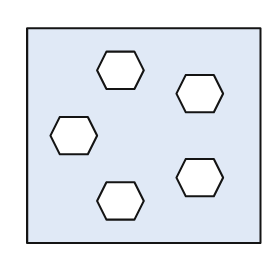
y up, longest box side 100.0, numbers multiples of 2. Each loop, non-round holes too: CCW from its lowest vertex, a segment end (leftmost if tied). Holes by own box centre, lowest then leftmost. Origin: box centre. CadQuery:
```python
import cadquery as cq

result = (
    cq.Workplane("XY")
    .moveTo(-50.0, -46.0)
    .lineTo(50.0, -46.0)
    .lineTo(50.0, 46.0)
    .lineTo(-50.0, 46.0)
    .close()
    .moveTo(-16.0, -36.0)
    .lineTo(-4.0, -36.0)
    .lineTo(0.0, -28.0)
    .lineTo(-4.0, -20.0)
    .lineTo(-16.0, -20.0)
    .lineTo(-20.0, -28.0)
    .close()
    .moveTo(18.0, -26.0)
    .lineTo(30.0, -26.0)
    .lineTo(34.0, -18.0)
    .lineTo(30.0, -10.0)
    .lineTo(18.0, -10.0)
    .lineTo(14.0, -18.0)
    .close()
    .moveTo(-36.0, -8.0)
    .lineTo(-24.0, -8.0)
    .lineTo(-20.0, 0.0)
    .lineTo(-24.0, 8.0)
    .lineTo(-36.0, 8.0)
    .lineTo(-40.0, 0.0)
    .close()
    .moveTo(18.0, 10.0)
    .lineTo(30.0, 10.0)
    .lineTo(34.0, 18.0)
    .lineTo(30.0, 26.0)
    .lineTo(18.0, 26.0)
    .lineTo(14.0, 18.0)
    .close()
    .moveTo(-16.0, 20.0)
    .lineTo(-4.0, 20.0)
    .lineTo(0.0, 28.0)
    .lineTo(-4.0, 36.0)
    .lineTo(-16.0, 36.0)
    .lineTo(-20.0, 28.0)
    .close()
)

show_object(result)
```